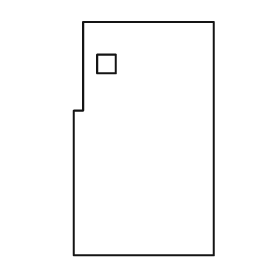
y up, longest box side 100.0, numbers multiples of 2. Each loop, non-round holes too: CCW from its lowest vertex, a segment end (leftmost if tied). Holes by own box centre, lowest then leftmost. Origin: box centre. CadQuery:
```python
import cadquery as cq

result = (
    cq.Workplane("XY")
    .moveTo(-30.0, -50.0)
    .lineTo(30.0, -50.0)
    .lineTo(30.0, 50.0)
    .lineTo(-26.0, 50.0)
    .lineTo(-26.0, 12.0)
    .lineTo(-30.0, 12.0)
    .close()
    .moveTo(-20.0, 28.0)
    .lineTo(-12.0, 28.0)
    .lineTo(-12.0, 36.0)
    .lineTo(-20.0, 36.0)
    .close()
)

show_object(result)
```